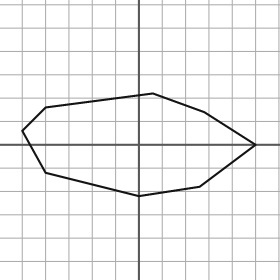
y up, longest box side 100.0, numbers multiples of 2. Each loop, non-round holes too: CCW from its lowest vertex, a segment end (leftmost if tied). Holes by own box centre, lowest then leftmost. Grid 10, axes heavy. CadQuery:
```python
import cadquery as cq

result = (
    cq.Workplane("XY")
    .moveTo(0.0, -22.0)
    .lineTo(26.0, -18.0)
    .lineTo(50.0, 0.0)
    .lineTo(28.0, 14.0)
    .lineTo(6.0, 22.0)
    .lineTo(-40.0, 16.0)
    .lineTo(-50.0, 6.0)
    .lineTo(-40.0, -12.0)
    .close()
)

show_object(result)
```